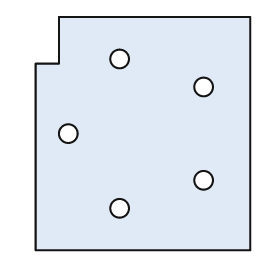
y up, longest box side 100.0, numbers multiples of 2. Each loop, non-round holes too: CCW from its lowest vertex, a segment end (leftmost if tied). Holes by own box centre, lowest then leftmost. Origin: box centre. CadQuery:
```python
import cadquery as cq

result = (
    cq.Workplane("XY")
    .moveTo(-46.0, -50.0)
    .lineTo(46.0, -50.0)
    .lineTo(46.0, 50.0)
    .lineTo(-36.0, 50.0)
    .lineTo(-36.0, 30.0)
    .lineTo(-46.0, 30.0)
    .close()
    .moveTo(-10.0, -32.0)
    .circle(4.0)
    .moveTo(26.0, -20.0)
    .circle(4.0)
    .moveTo(-32.0, 0.0)
    .circle(4.0)
    .moveTo(26.0, 20.0)
    .circle(4.0)
    .moveTo(-10.0, 32.0)
    .circle(4.0)
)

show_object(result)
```